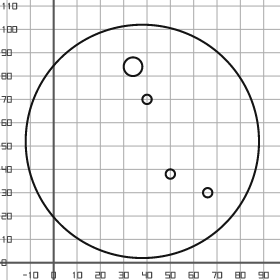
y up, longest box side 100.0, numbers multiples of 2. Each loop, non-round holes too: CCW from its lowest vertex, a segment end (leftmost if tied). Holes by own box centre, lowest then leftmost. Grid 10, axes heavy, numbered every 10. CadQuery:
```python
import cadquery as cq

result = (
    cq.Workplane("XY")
    .moveTo(38.0, 52.0)
    .circle(50.0)
    .moveTo(66.0, 30.0)
    .circle(2.0)
    .moveTo(50.0, 38.0)
    .circle(2.0)
    .moveTo(40.0, 70.0)
    .circle(2.0)
    .moveTo(34.0, 84.0)
    .circle(4.0)
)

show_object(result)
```